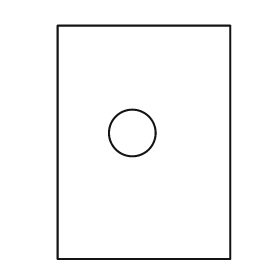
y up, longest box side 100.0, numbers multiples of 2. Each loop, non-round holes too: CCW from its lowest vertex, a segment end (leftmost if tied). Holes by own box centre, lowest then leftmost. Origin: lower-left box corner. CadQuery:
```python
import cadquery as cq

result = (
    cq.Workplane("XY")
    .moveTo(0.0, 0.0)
    .lineTo(74.0, 0.0)
    .lineTo(74.0, 100.0)
    .lineTo(0.0, 100.0)
    .close()
    .moveTo(32.0, 54.0)
    .circle(10.0)
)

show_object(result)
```